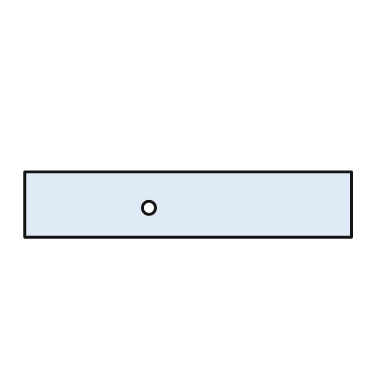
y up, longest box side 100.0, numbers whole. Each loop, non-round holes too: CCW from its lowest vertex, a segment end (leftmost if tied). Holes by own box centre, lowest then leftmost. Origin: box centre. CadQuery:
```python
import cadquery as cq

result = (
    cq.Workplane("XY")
    .moveTo(-50.0, -10.0)
    .lineTo(50.0, -10.0)
    .lineTo(50.0, 10.0)
    .lineTo(-50.0, 10.0)
    .close()
    .moveTo(-12.0, -1.0)
    .circle(2.0)
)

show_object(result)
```